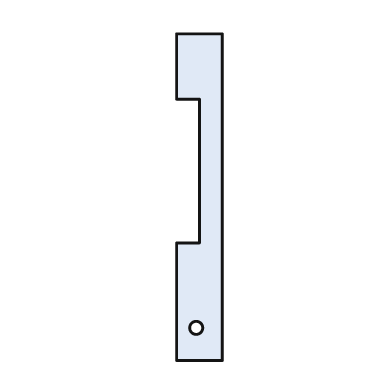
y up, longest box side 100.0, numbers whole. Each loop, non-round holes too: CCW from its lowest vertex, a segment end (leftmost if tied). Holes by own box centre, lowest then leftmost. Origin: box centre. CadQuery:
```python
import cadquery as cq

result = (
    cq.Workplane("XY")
    .moveTo(-7.0, -50.0)
    .lineTo(7.0, -50.0)
    .lineTo(7.0, 50.0)
    .lineTo(-7.0, 50.0)
    .lineTo(-7.0, 30.0)
    .lineTo(0.0, 30.0)
    .lineTo(0.0, -14.0)
    .lineTo(-7.0, -14.0)
    .close()
    .moveTo(-1.0, -40.0)
    .circle(2.0)
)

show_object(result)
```